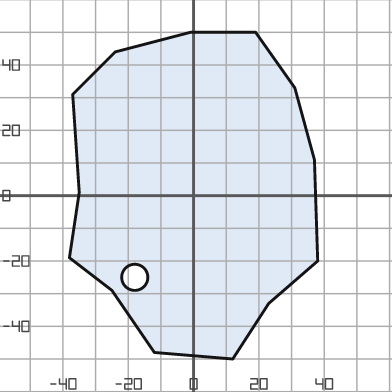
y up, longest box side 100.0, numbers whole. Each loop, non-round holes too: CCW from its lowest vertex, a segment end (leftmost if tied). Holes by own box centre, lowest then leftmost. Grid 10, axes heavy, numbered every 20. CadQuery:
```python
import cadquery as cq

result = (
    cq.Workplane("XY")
    .moveTo(12.0, -50.0)
    .lineTo(23.0, -33.0)
    .lineTo(38.0, -20.0)
    .lineTo(37.0, 11.0)
    .lineTo(31.0, 33.0)
    .lineTo(19.0, 50.0)
    .lineTo(-1.0, 50.0)
    .lineTo(-24.0, 44.0)
    .lineTo(-37.0, 31.0)
    .lineTo(-35.0, 1.0)
    .lineTo(-38.0, -19.0)
    .lineTo(-25.0, -29.0)
    .lineTo(-12.0, -48.0)
    .close()
    .moveTo(-18.0, -25.0)
    .circle(4.0)
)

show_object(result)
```